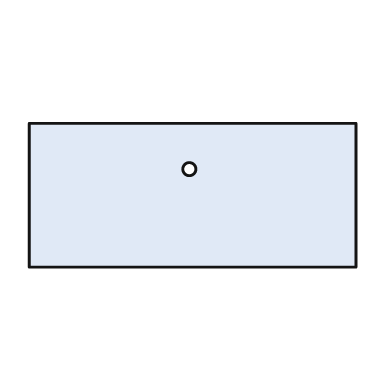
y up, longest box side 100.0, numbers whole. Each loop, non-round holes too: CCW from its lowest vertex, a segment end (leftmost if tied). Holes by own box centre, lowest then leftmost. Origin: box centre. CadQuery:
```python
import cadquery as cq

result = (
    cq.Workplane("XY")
    .moveTo(-50.0, -22.0)
    .lineTo(50.0, -22.0)
    .lineTo(50.0, 22.0)
    .lineTo(-50.0, 22.0)
    .close()
    .moveTo(-1.0, 8.0)
    .circle(2.0)
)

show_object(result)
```